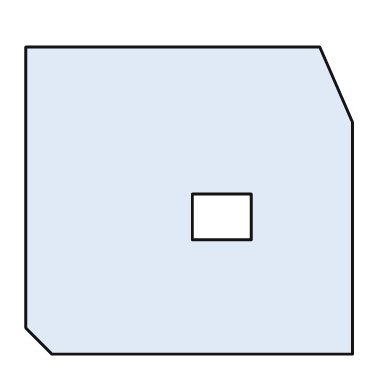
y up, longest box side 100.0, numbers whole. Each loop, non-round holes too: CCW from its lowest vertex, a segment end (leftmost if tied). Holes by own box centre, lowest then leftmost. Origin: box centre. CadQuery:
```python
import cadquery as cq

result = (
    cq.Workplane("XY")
    .moveTo(-42.0, -47.0)
    .lineTo(50.0, -47.0)
    .lineTo(50.0, 24.0)
    .lineTo(40.0, 47.0)
    .lineTo(-50.0, 47.0)
    .lineTo(-50.0, -39.0)
    .close()
    .moveTo(1.0, -12.0)
    .lineTo(19.0, -12.0)
    .lineTo(19.0, 2.0)
    .lineTo(1.0, 2.0)
    .close()
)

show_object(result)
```